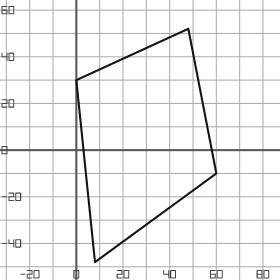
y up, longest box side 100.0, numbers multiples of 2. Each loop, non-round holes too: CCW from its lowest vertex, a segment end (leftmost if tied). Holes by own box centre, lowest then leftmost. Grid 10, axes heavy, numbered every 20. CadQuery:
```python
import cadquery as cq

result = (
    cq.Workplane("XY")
    .moveTo(8.0, -48.0)
    .lineTo(60.0, -10.0)
    .lineTo(48.0, 52.0)
    .lineTo(0.0, 30.0)
    .close()
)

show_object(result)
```